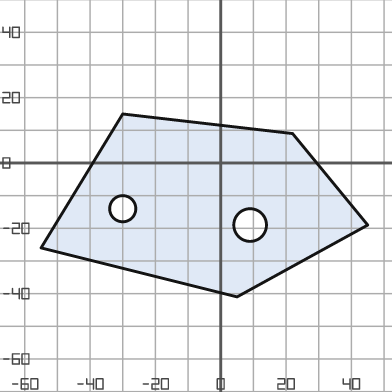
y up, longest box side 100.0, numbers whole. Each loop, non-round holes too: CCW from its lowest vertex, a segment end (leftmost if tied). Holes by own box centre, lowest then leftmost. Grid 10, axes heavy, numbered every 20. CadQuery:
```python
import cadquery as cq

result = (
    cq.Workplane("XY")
    .moveTo(5.0, -41.0)
    .lineTo(45.0, -19.0)
    .lineTo(22.0, 9.0)
    .lineTo(-30.0, 15.0)
    .lineTo(-55.0, -26.0)
    .close()
    .moveTo(9.0, -19.0)
    .circle(5.0)
    .moveTo(-30.0, -14.0)
    .circle(4.0)
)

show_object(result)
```